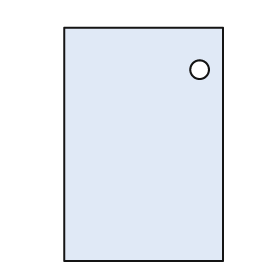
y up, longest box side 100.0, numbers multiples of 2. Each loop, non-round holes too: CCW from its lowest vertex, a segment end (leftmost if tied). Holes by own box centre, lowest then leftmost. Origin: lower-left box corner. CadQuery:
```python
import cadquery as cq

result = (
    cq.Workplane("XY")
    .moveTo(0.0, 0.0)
    .lineTo(68.0, 0.0)
    .lineTo(68.0, 100.0)
    .lineTo(0.0, 100.0)
    .close()
    .moveTo(58.0, 82.0)
    .circle(4.0)
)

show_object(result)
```